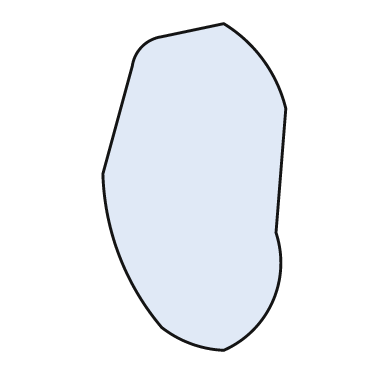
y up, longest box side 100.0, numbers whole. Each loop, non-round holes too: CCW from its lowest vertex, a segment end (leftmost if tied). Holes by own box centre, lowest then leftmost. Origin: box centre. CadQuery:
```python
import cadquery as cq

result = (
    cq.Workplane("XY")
    .moveTo(9.0, -50.0)
    .threePointArc((24.0, -35.0), (25.0, -14.0))
    .lineTo(28.0, 24.0)
    .threePointArc((21.0, 39.0), (9.0, 50.0))
    .lineTo(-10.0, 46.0)
    .threePointArc((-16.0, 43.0), (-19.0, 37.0))
    .lineTo(-28.0, 4.0)
    .threePointArc((-23.0, -21.0), (-10.0, -43.0))
    .threePointArc((-1.0, -48.0), (9.0, -50.0))
    .close()
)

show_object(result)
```